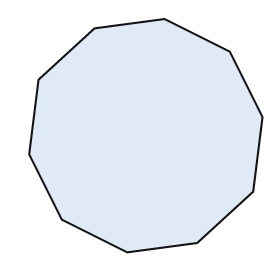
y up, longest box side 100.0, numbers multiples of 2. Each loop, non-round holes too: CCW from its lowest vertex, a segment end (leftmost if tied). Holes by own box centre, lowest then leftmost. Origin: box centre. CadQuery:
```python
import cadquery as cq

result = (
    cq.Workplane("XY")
    .moveTo(-8.0, -50.0)
    .lineTo(22.0, -46.0)
    .lineTo(46.0, -24.0)
    .lineTo(50.0, 8.0)
    .lineTo(36.0, 36.0)
    .lineTo(8.0, 50.0)
    .lineTo(-22.0, 46.0)
    .lineTo(-46.0, 24.0)
    .lineTo(-50.0, -8.0)
    .lineTo(-36.0, -36.0)
    .close()
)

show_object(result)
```